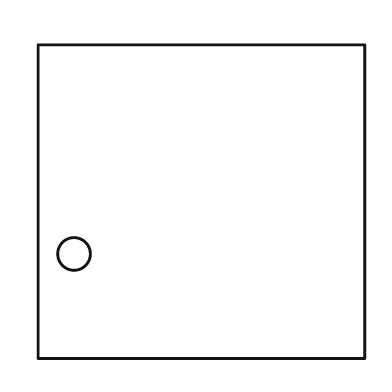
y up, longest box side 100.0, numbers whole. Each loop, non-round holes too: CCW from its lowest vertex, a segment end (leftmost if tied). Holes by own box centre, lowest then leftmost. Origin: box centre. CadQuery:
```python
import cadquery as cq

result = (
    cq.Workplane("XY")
    .moveTo(-50.0, -48.0)
    .lineTo(50.0, -48.0)
    .lineTo(50.0, 48.0)
    .lineTo(-50.0, 48.0)
    .close()
    .moveTo(-39.0, -16.0)
    .circle(5.0)
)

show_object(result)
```